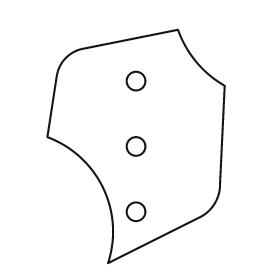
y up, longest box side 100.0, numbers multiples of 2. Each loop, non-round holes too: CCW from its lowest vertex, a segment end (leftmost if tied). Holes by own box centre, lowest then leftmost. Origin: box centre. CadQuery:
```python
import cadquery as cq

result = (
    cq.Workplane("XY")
    .moveTo(-12.0, -50.0)
    .lineTo(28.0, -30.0)
    .threePointArc((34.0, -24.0), (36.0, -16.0))
    .lineTo(38.0, 26.0)
    .threePointArc((26.0, 36.0), (18.0, 50.0))
    .lineTo(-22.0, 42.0)
    .threePointArc((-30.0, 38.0), (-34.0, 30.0))
    .lineTo(-38.0, 4.0)
    .threePointArc((-14.0, -18.0), (-12.0, -50.0))
    .close()
    .moveTo(0.0, -28.0)
    .circle(4.0)
    .moveTo(0.0, 0.0)
    .circle(4.0)
    .moveTo(0.0, 28.0)
    .circle(4.0)
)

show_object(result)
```